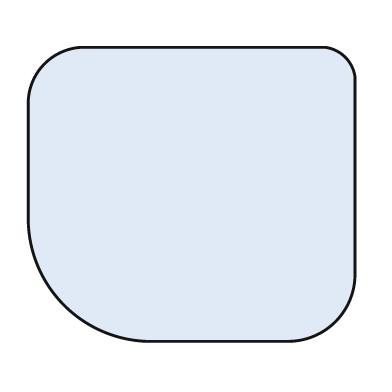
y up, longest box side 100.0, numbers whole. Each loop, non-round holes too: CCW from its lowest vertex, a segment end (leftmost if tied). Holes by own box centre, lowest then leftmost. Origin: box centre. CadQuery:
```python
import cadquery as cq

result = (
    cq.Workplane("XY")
    .moveTo(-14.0, -45.0)
    .lineTo(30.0, -45.0)
    .threePointArc((44.0, -39.0), (50.0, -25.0))
    .lineTo(50.0, 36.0)
    .threePointArc((47.0, 42.0), (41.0, 45.0))
    .lineTo(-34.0, 45.0)
    .threePointArc((-45.0, 40.0), (-50.0, 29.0))
    .lineTo(-50.0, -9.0)
    .threePointArc((-39.0, -34.0), (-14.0, -45.0))
    .close()
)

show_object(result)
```